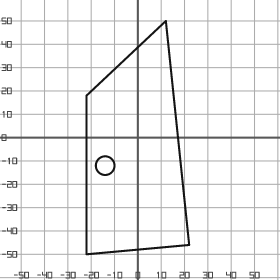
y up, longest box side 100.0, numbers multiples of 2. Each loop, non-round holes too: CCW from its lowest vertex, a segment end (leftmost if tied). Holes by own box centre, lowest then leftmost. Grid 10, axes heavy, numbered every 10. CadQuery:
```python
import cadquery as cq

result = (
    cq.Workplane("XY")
    .moveTo(-22.0, -50.0)
    .lineTo(22.0, -46.0)
    .lineTo(12.0, 50.0)
    .lineTo(-22.0, 18.0)
    .close()
    .moveTo(-14.0, -12.0)
    .circle(4.0)
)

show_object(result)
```